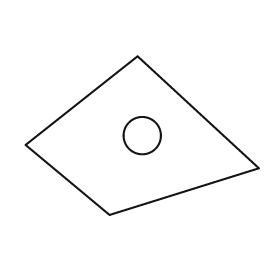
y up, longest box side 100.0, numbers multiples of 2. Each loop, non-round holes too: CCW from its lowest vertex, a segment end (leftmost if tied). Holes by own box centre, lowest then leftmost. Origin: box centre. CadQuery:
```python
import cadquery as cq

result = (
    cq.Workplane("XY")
    .moveTo(-14.0, -34.0)
    .lineTo(50.0, -14.0)
    .lineTo(-2.0, 34.0)
    .lineTo(-50.0, -4.0)
    .close()
    .moveTo(0.0, 0.0)
    .circle(8.0)
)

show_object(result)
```